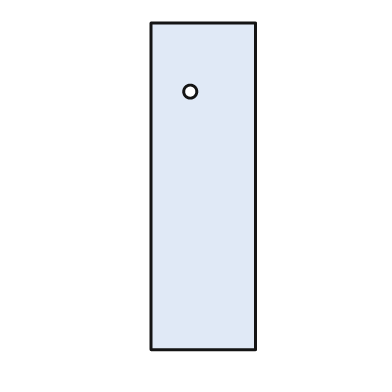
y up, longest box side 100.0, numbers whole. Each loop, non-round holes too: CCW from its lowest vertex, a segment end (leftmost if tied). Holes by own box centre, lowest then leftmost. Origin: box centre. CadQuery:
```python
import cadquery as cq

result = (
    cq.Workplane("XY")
    .moveTo(-16.0, -50.0)
    .lineTo(16.0, -50.0)
    .lineTo(16.0, 50.0)
    .lineTo(-16.0, 50.0)
    .close()
    .moveTo(-4.0, 29.0)
    .circle(2.0)
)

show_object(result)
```